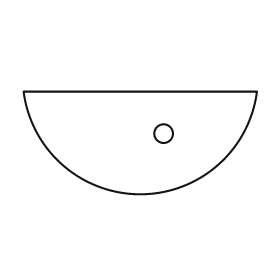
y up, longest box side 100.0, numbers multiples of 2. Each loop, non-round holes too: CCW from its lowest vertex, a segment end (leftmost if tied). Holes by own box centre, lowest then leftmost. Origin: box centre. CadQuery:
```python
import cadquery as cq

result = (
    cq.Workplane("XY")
    .moveTo(-50.0, 22.0)
    .threePointArc((0.0, -22.0), (50.0, 22.0))
    .close()
    .moveTo(10.0, 4.0)
    .circle(4.0)
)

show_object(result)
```